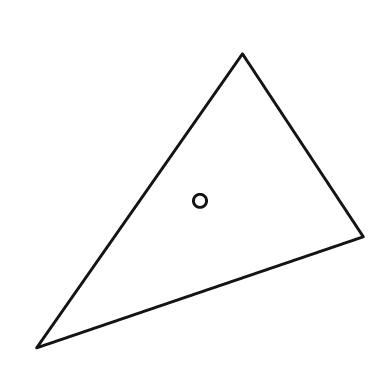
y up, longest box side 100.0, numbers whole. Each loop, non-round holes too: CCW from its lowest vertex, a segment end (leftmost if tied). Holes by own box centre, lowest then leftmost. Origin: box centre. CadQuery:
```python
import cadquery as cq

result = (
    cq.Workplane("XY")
    .moveTo(-50.0, -45.0)
    .lineTo(50.0, -11.0)
    .lineTo(13.0, 45.0)
    .close()
    .moveTo(0.0, 0.0)
    .circle(2.0)
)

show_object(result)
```